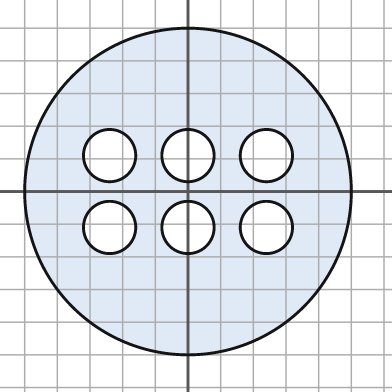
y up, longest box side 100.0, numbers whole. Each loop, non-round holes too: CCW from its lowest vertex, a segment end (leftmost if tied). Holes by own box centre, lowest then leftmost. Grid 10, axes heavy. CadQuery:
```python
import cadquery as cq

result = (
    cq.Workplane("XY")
    .moveTo(0.0, 0.0)
    .circle(50.0)
    .moveTo(-24.0, -11.0)
    .circle(8.0)
    .moveTo(0.0, -11.0)
    .circle(8.0)
    .moveTo(24.0, -11.0)
    .circle(8.0)
    .moveTo(-24.0, 11.0)
    .circle(8.0)
    .moveTo(0.0, 11.0)
    .circle(8.0)
    .moveTo(24.0, 11.0)
    .circle(8.0)
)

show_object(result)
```